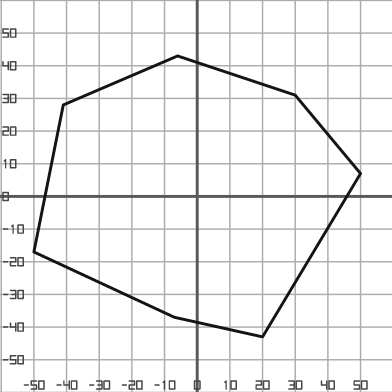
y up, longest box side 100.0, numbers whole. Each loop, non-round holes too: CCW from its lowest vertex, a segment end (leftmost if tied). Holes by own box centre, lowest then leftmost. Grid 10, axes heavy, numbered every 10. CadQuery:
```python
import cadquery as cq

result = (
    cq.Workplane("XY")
    .moveTo(20.0, -43.0)
    .lineTo(50.0, 7.0)
    .lineTo(30.0, 31.0)
    .lineTo(-6.0, 43.0)
    .lineTo(-41.0, 28.0)
    .lineTo(-50.0, -17.0)
    .lineTo(-7.0, -37.0)
    .close()
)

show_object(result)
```